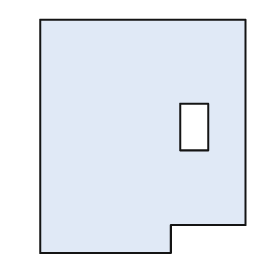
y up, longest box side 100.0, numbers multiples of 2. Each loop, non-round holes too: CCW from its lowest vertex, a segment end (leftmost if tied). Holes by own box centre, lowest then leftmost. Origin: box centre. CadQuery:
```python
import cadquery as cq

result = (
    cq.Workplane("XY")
    .moveTo(-44.0, -50.0)
    .lineTo(12.0, -50.0)
    .lineTo(12.0, -38.0)
    .lineTo(44.0, -38.0)
    .lineTo(44.0, 50.0)
    .lineTo(-44.0, 50.0)
    .close()
    .moveTo(16.0, -6.0)
    .lineTo(28.0, -6.0)
    .lineTo(28.0, 14.0)
    .lineTo(16.0, 14.0)
    .close()
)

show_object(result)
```